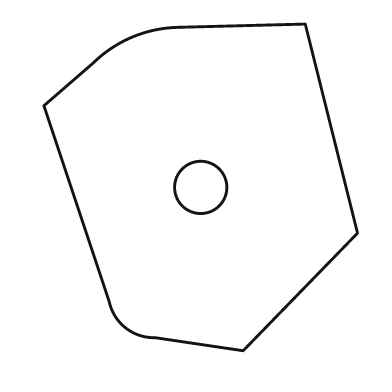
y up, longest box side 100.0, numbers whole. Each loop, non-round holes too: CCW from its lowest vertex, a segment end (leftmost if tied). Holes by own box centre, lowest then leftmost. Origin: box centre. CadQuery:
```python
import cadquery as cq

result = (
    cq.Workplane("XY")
    .moveTo(13.0, -50.0)
    .lineTo(48.0, -14.0)
    .lineTo(32.0, 50.0)
    .lineTo(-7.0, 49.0)
    .threePointArc((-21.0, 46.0), (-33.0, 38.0))
    .lineTo(-48.0, 25.0)
    .lineTo(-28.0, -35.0)
    .threePointArc((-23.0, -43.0), (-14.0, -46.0))
    .close()
    .moveTo(0.0, 0.0)
    .circle(8.0)
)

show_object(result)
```